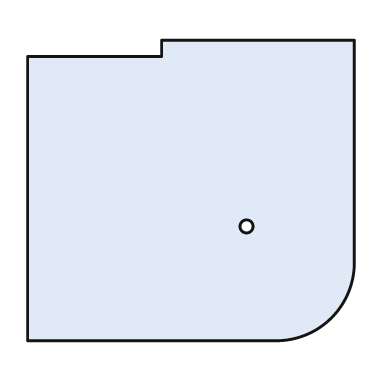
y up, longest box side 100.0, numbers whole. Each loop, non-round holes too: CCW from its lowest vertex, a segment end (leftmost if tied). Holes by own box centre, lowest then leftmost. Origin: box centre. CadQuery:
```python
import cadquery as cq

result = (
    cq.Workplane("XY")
    .moveTo(-50.0, -46.0)
    .lineTo(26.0, -46.0)
    .threePointArc((43.0, -39.0), (50.0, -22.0))
    .lineTo(50.0, 46.0)
    .lineTo(-9.0, 46.0)
    .lineTo(-9.0, 41.0)
    .lineTo(-50.0, 41.0)
    .close()
    .moveTo(17.0, -11.0)
    .circle(2.0)
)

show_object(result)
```